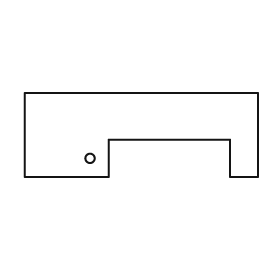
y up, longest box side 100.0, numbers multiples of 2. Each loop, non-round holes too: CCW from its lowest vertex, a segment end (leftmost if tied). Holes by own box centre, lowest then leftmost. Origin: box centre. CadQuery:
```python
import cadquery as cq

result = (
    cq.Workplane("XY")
    .moveTo(-50.0, -18.0)
    .lineTo(-14.0, -18.0)
    .lineTo(-14.0, -2.0)
    .lineTo(38.0, -2.0)
    .lineTo(38.0, -18.0)
    .lineTo(50.0, -18.0)
    .lineTo(50.0, 18.0)
    .lineTo(-50.0, 18.0)
    .close()
    .moveTo(-22.0, -10.0)
    .circle(2.0)
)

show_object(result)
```